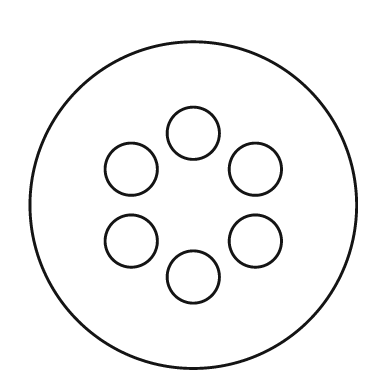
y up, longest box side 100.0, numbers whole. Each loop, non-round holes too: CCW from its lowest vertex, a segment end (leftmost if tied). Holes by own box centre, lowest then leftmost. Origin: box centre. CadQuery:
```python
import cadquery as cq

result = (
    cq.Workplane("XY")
    .moveTo(0.0, 0.0)
    .circle(50.0)
    .moveTo(0.0, -22.0)
    .circle(8.0)
    .moveTo(-19.0, -11.0)
    .circle(8.0)
    .moveTo(19.0, -11.0)
    .circle(8.0)
    .moveTo(-19.0, 11.0)
    .circle(8.0)
    .moveTo(19.0, 11.0)
    .circle(8.0)
    .moveTo(0.0, 22.0)
    .circle(8.0)
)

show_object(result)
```